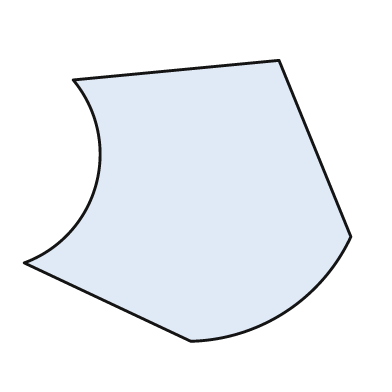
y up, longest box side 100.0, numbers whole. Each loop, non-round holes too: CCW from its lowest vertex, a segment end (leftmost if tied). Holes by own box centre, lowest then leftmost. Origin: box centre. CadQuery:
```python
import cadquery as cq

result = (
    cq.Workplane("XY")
    .moveTo(1.0, -43.0)
    .threePointArc((30.0, -34.0), (50.0, -11.0))
    .lineTo(28.0, 43.0)
    .lineTo(-35.0, 37.0)
    .threePointArc((-28.0, 5.0), (-50.0, -19.0))
    .close()
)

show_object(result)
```